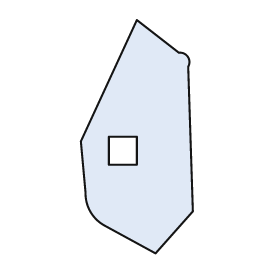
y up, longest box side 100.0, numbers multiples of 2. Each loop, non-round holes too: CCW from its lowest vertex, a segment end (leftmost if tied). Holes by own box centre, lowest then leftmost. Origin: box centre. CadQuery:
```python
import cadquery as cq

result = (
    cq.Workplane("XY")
    .moveTo(8.0, -50.0)
    .lineTo(24.0, -32.0)
    .lineTo(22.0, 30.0)
    .threePointArc((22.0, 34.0), (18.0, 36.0))
    .lineTo(0.0, 50.0)
    .lineTo(-24.0, -2.0)
    .lineTo(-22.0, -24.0)
    .threePointArc((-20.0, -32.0), (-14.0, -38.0))
    .close()
    .moveTo(-12.0, -12.0)
    .lineTo(0.0, -12.0)
    .lineTo(0.0, 0.0)
    .lineTo(-12.0, 0.0)
    .close()
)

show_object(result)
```